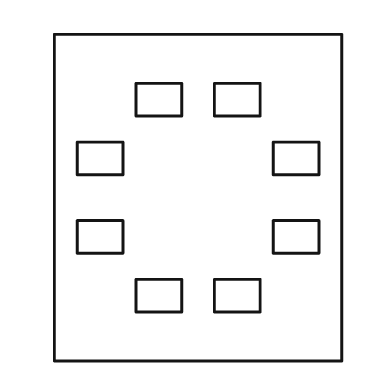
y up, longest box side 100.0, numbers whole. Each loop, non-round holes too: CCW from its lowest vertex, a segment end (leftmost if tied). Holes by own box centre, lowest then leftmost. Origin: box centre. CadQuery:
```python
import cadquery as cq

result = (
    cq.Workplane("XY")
    .moveTo(-44.0, -50.0)
    .lineTo(44.0, -50.0)
    .lineTo(44.0, 50.0)
    .lineTo(-44.0, 50.0)
    .close()
    .moveTo(-19.0, -35.0)
    .lineTo(-5.0, -35.0)
    .lineTo(-5.0, -25.0)
    .lineTo(-19.0, -25.0)
    .close()
    .moveTo(5.0, -35.0)
    .lineTo(19.0, -35.0)
    .lineTo(19.0, -25.0)
    .lineTo(5.0, -25.0)
    .close()
    .moveTo(-37.0, -17.0)
    .lineTo(-23.0, -17.0)
    .lineTo(-23.0, -7.0)
    .lineTo(-37.0, -7.0)
    .close()
    .moveTo(23.0, -17.0)
    .lineTo(37.0, -17.0)
    .lineTo(37.0, -7.0)
    .lineTo(23.0, -7.0)
    .close()
    .moveTo(-37.0, 7.0)
    .lineTo(-23.0, 7.0)
    .lineTo(-23.0, 17.0)
    .lineTo(-37.0, 17.0)
    .close()
    .moveTo(23.0, 7.0)
    .lineTo(37.0, 7.0)
    .lineTo(37.0, 17.0)
    .lineTo(23.0, 17.0)
    .close()
    .moveTo(-19.0, 25.0)
    .lineTo(-5.0, 25.0)
    .lineTo(-5.0, 35.0)
    .lineTo(-19.0, 35.0)
    .close()
    .moveTo(5.0, 25.0)
    .lineTo(19.0, 25.0)
    .lineTo(19.0, 35.0)
    .lineTo(5.0, 35.0)
    .close()
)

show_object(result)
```